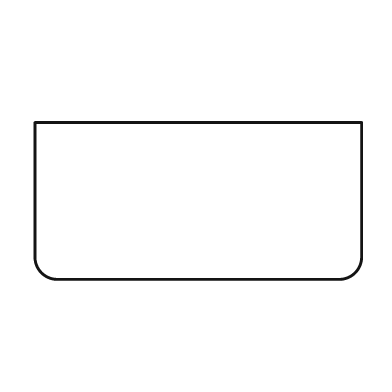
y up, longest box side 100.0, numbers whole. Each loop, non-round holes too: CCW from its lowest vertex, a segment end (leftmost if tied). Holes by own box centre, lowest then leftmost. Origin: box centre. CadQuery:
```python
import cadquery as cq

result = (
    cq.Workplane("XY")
    .moveTo(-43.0, -24.0)
    .lineTo(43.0, -24.0)
    .threePointArc((48.0, -22.0), (50.0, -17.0))
    .lineTo(50.0, 24.0)
    .lineTo(-50.0, 24.0)
    .lineTo(-50.0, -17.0)
    .threePointArc((-48.0, -22.0), (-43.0, -24.0))
    .close()
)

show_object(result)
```